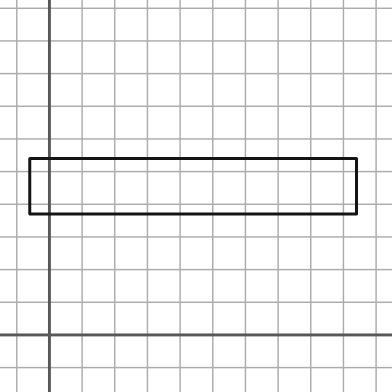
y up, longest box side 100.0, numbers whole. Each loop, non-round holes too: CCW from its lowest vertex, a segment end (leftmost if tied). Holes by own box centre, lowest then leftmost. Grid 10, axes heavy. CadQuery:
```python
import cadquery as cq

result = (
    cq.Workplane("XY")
    .moveTo(-6.0, 37.0)
    .lineTo(94.0, 37.0)
    .lineTo(94.0, 54.0)
    .lineTo(-6.0, 54.0)
    .close()
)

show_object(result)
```